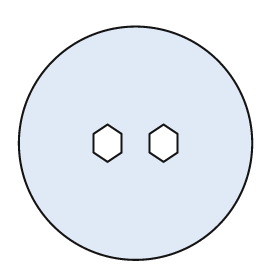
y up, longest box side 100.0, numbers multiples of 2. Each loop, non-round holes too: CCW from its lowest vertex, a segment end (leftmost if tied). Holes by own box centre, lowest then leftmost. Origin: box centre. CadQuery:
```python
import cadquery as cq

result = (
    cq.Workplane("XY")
    .moveTo(0.0, 0.0)
    .circle(50.0)
    .moveTo(-12.0, -8.0)
    .lineTo(-6.0, -4.0)
    .lineTo(-6.0, 4.0)
    .lineTo(-12.0, 8.0)
    .lineTo(-18.0, 4.0)
    .lineTo(-18.0, -4.0)
    .close()
    .moveTo(12.0, -8.0)
    .lineTo(18.0, -4.0)
    .lineTo(18.0, 4.0)
    .lineTo(12.0, 8.0)
    .lineTo(6.0, 4.0)
    .lineTo(6.0, -4.0)
    .close()
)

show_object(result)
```